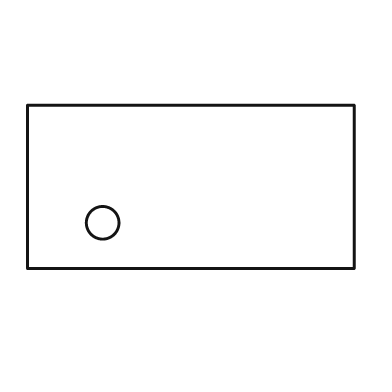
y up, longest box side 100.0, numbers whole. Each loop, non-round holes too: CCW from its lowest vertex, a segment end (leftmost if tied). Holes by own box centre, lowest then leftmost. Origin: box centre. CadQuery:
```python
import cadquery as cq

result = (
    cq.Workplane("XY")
    .moveTo(-50.0, -25.0)
    .lineTo(50.0, -25.0)
    .lineTo(50.0, 25.0)
    .lineTo(-50.0, 25.0)
    .close()
    .moveTo(-27.0, -11.0)
    .circle(5.0)
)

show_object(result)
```